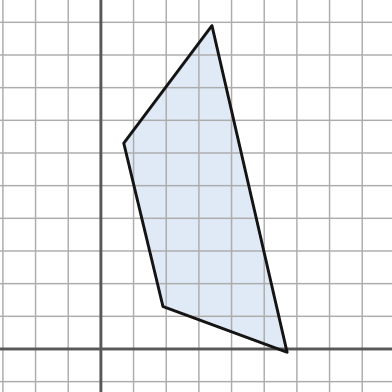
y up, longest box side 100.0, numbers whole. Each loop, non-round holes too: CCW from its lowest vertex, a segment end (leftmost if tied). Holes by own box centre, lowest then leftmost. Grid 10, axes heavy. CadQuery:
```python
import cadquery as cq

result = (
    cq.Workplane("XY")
    .moveTo(57.0, -1.0)
    .lineTo(34.0, 99.0)
    .lineTo(7.0, 63.0)
    .lineTo(19.0, 13.0)
    .close()
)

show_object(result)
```